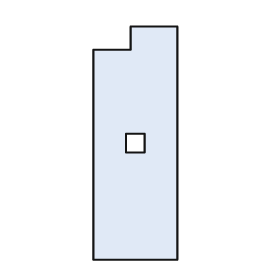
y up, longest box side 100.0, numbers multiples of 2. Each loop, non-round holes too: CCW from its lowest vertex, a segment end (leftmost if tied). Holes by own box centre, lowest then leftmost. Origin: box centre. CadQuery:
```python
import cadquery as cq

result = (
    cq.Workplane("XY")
    .moveTo(-18.0, -50.0)
    .lineTo(18.0, -50.0)
    .lineTo(18.0, 50.0)
    .lineTo(-2.0, 50.0)
    .lineTo(-2.0, 40.0)
    .lineTo(-18.0, 40.0)
    .close()
    .moveTo(-4.0, -4.0)
    .lineTo(4.0, -4.0)
    .lineTo(4.0, 4.0)
    .lineTo(-4.0, 4.0)
    .close()
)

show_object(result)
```